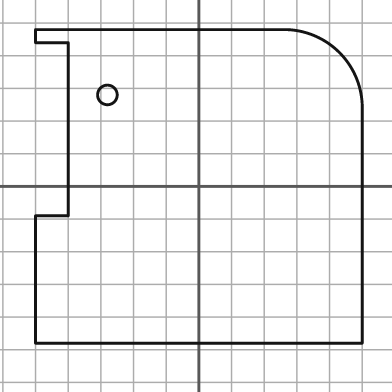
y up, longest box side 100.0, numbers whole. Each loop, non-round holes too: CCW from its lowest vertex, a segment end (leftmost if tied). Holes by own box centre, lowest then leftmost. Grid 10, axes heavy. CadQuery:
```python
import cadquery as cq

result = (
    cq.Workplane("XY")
    .moveTo(-50.0, -48.0)
    .lineTo(50.0, -48.0)
    .lineTo(50.0, 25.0)
    .threePointArc((43.0, 41.0), (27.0, 48.0))
    .lineTo(-50.0, 48.0)
    .lineTo(-50.0, 44.0)
    .lineTo(-40.0, 44.0)
    .lineTo(-40.0, -9.0)
    .lineTo(-50.0, -9.0)
    .close()
    .moveTo(-28.0, 28.0)
    .circle(3.0)
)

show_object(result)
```